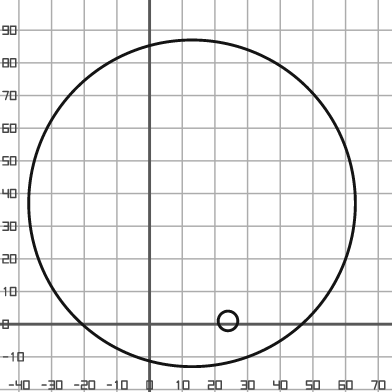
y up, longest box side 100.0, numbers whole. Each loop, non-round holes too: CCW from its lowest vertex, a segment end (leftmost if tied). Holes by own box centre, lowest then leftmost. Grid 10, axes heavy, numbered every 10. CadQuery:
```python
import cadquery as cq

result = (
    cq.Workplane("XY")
    .moveTo(13.0, 37.0)
    .circle(50.0)
    .moveTo(24.0, 1.0)
    .circle(3.0)
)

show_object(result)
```